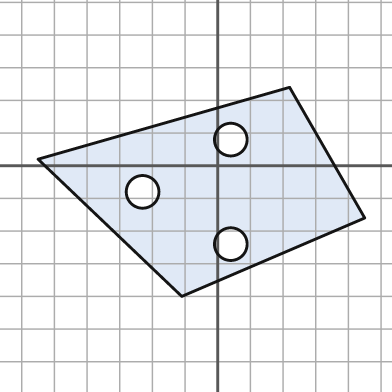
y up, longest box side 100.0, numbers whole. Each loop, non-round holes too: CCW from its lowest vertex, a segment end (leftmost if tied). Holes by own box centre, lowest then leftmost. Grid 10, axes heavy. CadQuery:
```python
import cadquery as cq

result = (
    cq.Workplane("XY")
    .moveTo(-11.0, -40.0)
    .lineTo(45.0, -16.0)
    .lineTo(22.0, 24.0)
    .lineTo(-55.0, 2.0)
    .close()
    .moveTo(4.0, -24.0)
    .circle(5.0)
    .moveTo(-23.0, -8.0)
    .circle(5.0)
    .moveTo(4.0, 8.0)
    .circle(5.0)
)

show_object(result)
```